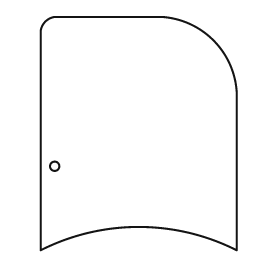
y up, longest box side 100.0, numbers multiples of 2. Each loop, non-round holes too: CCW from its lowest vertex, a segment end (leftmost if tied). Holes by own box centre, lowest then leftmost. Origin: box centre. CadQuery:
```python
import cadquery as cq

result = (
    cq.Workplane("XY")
    .moveTo(-42.0, -50.0)
    .threePointArc((0.0, -40.0), (42.0, -50.0))
    .lineTo(42.0, 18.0)
    .threePointArc((32.0, 40.0), (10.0, 50.0))
    .lineTo(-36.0, 50.0)
    .threePointArc((-40.0, 48.0), (-42.0, 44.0))
    .close()
    .moveTo(-36.0, -14.0)
    .circle(2.0)
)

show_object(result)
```